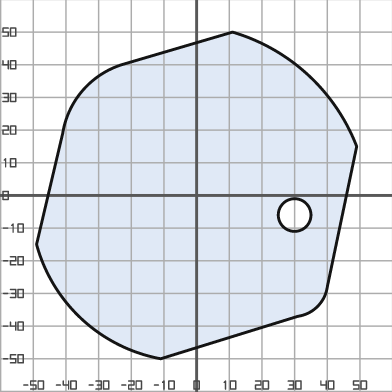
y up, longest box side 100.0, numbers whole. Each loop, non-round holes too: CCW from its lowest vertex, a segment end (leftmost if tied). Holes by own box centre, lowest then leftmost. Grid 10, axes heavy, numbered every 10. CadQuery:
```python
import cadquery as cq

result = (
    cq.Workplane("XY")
    .moveTo(-11.0, -50.0)
    .lineTo(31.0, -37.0)
    .threePointArc((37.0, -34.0), (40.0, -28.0))
    .lineTo(49.0, 15.0)
    .threePointArc((34.0, 37.0), (11.0, 50.0))
    .lineTo(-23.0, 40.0)
    .threePointArc((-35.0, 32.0), (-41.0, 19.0))
    .lineTo(-49.0, -15.0)
    .threePointArc((-35.0, -38.0), (-11.0, -50.0))
    .close()
    .moveTo(30.0, -6.0)
    .circle(5.0)
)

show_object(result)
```